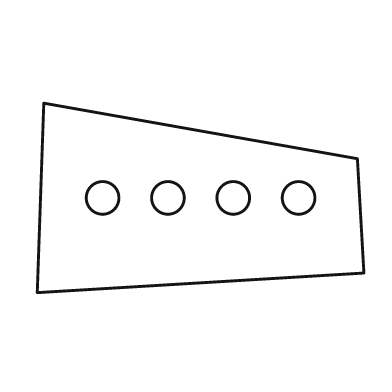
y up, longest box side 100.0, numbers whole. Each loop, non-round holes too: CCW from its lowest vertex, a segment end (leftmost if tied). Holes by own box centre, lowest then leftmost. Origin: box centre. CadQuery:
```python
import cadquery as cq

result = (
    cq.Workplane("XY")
    .moveTo(-50.0, -29.0)
    .lineTo(50.0, -23.0)
    .lineTo(48.0, 12.0)
    .lineTo(-48.0, 29.0)
    .close()
    .moveTo(-30.0, 0.0)
    .circle(5.0)
    .moveTo(-10.0, 0.0)
    .circle(5.0)
    .moveTo(10.0, 0.0)
    .circle(5.0)
    .moveTo(30.0, 0.0)
    .circle(5.0)
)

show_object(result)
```